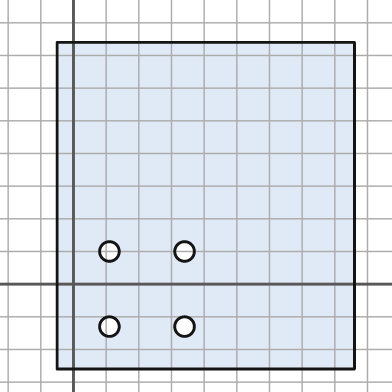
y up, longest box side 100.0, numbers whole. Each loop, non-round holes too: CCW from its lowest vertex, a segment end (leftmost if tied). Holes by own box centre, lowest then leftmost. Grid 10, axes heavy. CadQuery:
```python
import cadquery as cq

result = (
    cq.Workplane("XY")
    .moveTo(-5.0, -26.0)
    .lineTo(86.0, -26.0)
    .lineTo(86.0, 74.0)
    .lineTo(-5.0, 74.0)
    .close()
    .moveTo(11.0, -13.0)
    .circle(3.0)
    .moveTo(34.0, -13.0)
    .circle(3.0)
    .moveTo(11.0, 10.0)
    .circle(3.0)
    .moveTo(34.0, 10.0)
    .circle(3.0)
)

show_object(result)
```